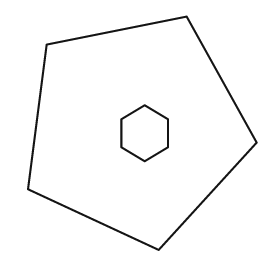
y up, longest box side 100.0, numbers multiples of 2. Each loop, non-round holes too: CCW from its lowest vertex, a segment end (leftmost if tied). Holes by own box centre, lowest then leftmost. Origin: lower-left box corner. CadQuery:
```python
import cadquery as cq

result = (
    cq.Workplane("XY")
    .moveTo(56.0, 0.0)
    .lineTo(98.0, 46.0)
    .lineTo(68.0, 100.0)
    .lineTo(8.0, 88.0)
    .lineTo(0.0, 26.0)
    .close()
    .moveTo(50.0, 38.0)
    .lineTo(60.0, 44.0)
    .lineTo(60.0, 56.0)
    .lineTo(50.0, 62.0)
    .lineTo(40.0, 56.0)
    .lineTo(40.0, 44.0)
    .close()
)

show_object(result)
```